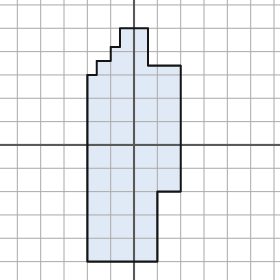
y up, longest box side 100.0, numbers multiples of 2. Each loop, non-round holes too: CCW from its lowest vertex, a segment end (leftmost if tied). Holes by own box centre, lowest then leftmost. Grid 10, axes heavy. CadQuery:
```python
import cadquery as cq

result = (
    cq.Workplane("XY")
    .moveTo(-20.0, -50.0)
    .lineTo(10.0, -50.0)
    .lineTo(10.0, -20.0)
    .lineTo(20.0, -20.0)
    .lineTo(20.0, 34.0)
    .lineTo(6.0, 34.0)
    .lineTo(6.0, 50.0)
    .lineTo(-6.0, 50.0)
    .lineTo(-6.0, 42.0)
    .lineTo(-10.0, 42.0)
    .lineTo(-10.0, 36.0)
    .lineTo(-16.0, 36.0)
    .lineTo(-16.0, 30.0)
    .lineTo(-20.0, 30.0)
    .close()
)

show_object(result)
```